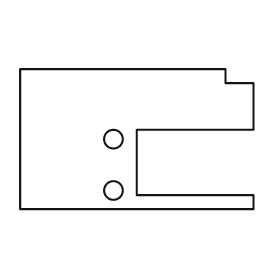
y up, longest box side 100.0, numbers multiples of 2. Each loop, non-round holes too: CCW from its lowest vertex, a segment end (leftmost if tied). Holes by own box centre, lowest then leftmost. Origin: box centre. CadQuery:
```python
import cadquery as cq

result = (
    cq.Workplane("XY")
    .moveTo(-50.0, -30.0)
    .lineTo(50.0, -30.0)
    .lineTo(50.0, -24.0)
    .lineTo(0.0, -24.0)
    .lineTo(0.0, 4.0)
    .lineTo(50.0, 4.0)
    .lineTo(50.0, 24.0)
    .lineTo(38.0, 24.0)
    .lineTo(38.0, 30.0)
    .lineTo(-50.0, 30.0)
    .close()
    .moveTo(-10.0, -22.0)
    .circle(4.0)
    .moveTo(-10.0, 0.0)
    .circle(4.0)
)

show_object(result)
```